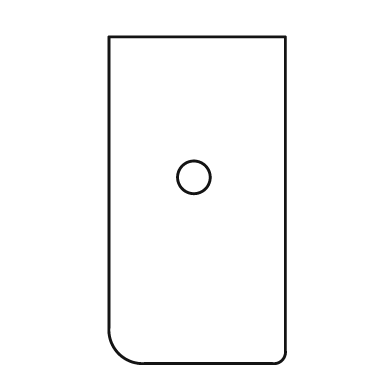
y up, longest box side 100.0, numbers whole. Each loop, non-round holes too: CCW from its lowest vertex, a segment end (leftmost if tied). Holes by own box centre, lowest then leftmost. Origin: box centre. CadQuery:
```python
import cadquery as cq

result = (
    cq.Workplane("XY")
    .moveTo(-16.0, -50.0)
    .lineTo(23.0, -50.0)
    .threePointArc((26.0, -49.0), (27.0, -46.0))
    .lineTo(27.0, 50.0)
    .lineTo(-27.0, 50.0)
    .lineTo(-27.0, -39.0)
    .threePointArc((-24.0, -47.0), (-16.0, -50.0))
    .close()
    .moveTo(-1.0, 7.0)
    .circle(5.0)
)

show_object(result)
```